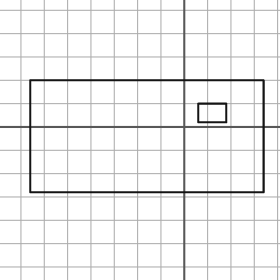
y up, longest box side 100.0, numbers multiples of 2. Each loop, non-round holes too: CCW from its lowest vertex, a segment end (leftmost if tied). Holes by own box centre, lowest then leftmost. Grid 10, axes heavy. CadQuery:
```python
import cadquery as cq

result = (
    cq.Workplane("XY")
    .moveTo(-66.0, -28.0)
    .lineTo(34.0, -28.0)
    .lineTo(34.0, 20.0)
    .lineTo(-66.0, 20.0)
    .close()
    .moveTo(6.0, 2.0)
    .lineTo(18.0, 2.0)
    .lineTo(18.0, 10.0)
    .lineTo(6.0, 10.0)
    .close()
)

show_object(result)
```